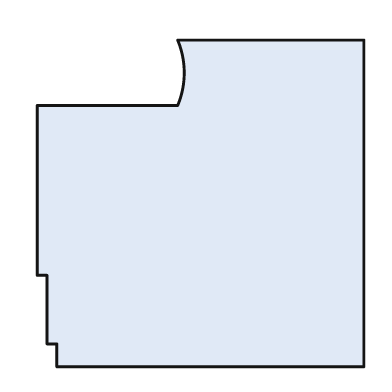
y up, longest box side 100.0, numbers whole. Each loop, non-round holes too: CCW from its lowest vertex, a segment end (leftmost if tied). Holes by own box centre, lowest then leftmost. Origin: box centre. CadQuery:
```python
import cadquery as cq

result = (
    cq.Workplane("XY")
    .moveTo(-44.0, -50.0)
    .lineTo(50.0, -50.0)
    .lineTo(50.0, 50.0)
    .lineTo(-7.0, 50.0)
    .threePointArc((-5.0, 40.0), (-7.0, 30.0))
    .lineTo(-50.0, 30.0)
    .lineTo(-50.0, -22.0)
    .lineTo(-47.0, -22.0)
    .lineTo(-47.0, -43.0)
    .lineTo(-44.0, -43.0)
    .close()
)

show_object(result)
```